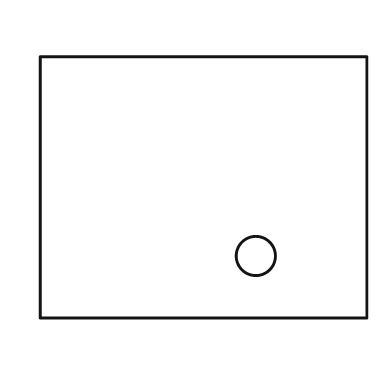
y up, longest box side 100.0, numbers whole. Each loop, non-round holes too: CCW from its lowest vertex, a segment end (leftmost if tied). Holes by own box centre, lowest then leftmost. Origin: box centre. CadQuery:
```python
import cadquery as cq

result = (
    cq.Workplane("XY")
    .moveTo(-50.0, -40.0)
    .lineTo(50.0, -40.0)
    .lineTo(50.0, 40.0)
    .lineTo(-50.0, 40.0)
    .close()
    .moveTo(16.0, -21.0)
    .circle(6.0)
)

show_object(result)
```